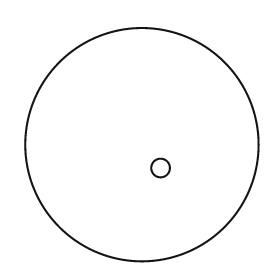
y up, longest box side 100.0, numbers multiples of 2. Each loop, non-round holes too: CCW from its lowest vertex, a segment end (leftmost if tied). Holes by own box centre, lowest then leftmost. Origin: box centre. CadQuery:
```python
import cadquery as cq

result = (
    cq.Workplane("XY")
    .moveTo(0.0, 0.0)
    .circle(50.0)
    .moveTo(8.0, -10.0)
    .circle(4.0)
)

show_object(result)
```